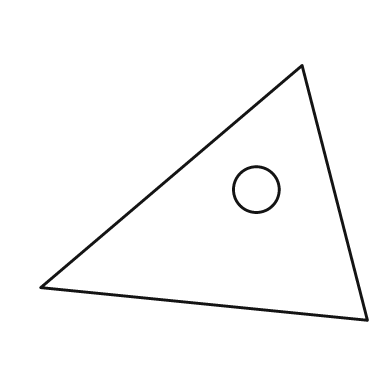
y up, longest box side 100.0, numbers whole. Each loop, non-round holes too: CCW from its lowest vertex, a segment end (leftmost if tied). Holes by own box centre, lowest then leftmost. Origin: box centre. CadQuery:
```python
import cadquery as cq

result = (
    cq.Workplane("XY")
    .moveTo(50.0, -39.0)
    .lineTo(30.0, 39.0)
    .lineTo(-50.0, -29.0)
    .close()
    .moveTo(16.0, 1.0)
    .circle(7.0)
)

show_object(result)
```